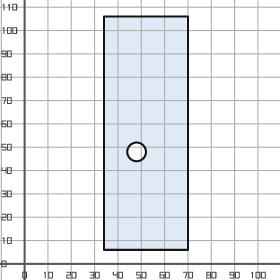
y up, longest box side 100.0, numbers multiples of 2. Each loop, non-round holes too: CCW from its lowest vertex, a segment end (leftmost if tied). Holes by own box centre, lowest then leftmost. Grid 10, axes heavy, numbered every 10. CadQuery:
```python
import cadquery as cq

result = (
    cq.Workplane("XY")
    .moveTo(34.0, 6.0)
    .lineTo(70.0, 6.0)
    .lineTo(70.0, 106.0)
    .lineTo(34.0, 106.0)
    .close()
    .moveTo(48.0, 48.0)
    .circle(4.0)
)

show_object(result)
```